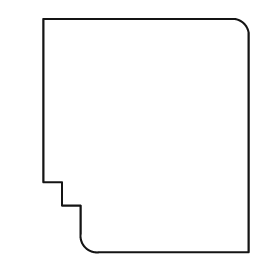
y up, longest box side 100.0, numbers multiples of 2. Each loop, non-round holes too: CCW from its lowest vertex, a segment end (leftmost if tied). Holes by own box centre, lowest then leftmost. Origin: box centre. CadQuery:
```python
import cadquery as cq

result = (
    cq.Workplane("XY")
    .moveTo(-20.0, -50.0)
    .lineTo(44.0, -50.0)
    .lineTo(44.0, 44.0)
    .threePointArc((42.0, 48.0), (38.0, 50.0))
    .lineTo(-44.0, 50.0)
    .lineTo(-44.0, -20.0)
    .lineTo(-36.0, -20.0)
    .lineTo(-36.0, -30.0)
    .lineTo(-28.0, -30.0)
    .lineTo(-28.0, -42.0)
    .threePointArc((-26.0, -48.0), (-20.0, -50.0))
    .close()
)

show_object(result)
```